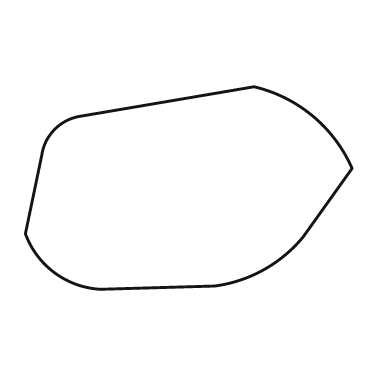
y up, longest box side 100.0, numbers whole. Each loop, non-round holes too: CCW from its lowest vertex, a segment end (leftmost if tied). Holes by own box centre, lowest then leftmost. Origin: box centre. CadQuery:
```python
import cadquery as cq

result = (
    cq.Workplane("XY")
    .moveTo(-27.0, -31.0)
    .lineTo(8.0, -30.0)
    .threePointArc((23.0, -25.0), (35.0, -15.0))
    .lineTo(50.0, 6.0)
    .threePointArc((38.0, 22.0), (20.0, 31.0))
    .lineTo(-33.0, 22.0)
    .threePointArc((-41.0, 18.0), (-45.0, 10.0))
    .lineTo(-50.0, -14.0)
    .threePointArc((-41.0, -26.0), (-27.0, -31.0))
    .close()
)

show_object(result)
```